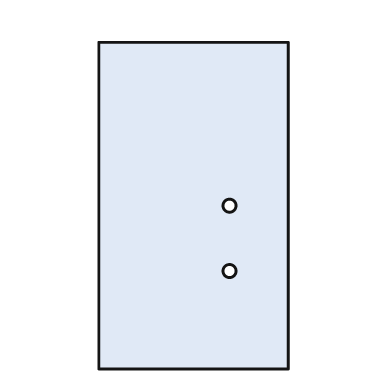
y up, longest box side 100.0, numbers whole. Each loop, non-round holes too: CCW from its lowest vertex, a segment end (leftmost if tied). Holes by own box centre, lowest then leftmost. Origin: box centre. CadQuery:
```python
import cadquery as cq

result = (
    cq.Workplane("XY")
    .moveTo(-29.0, -50.0)
    .lineTo(29.0, -50.0)
    .lineTo(29.0, 50.0)
    .lineTo(-29.0, 50.0)
    .close()
    .moveTo(11.0, -20.0)
    .circle(2.0)
    .moveTo(11.0, 0.0)
    .circle(2.0)
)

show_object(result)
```